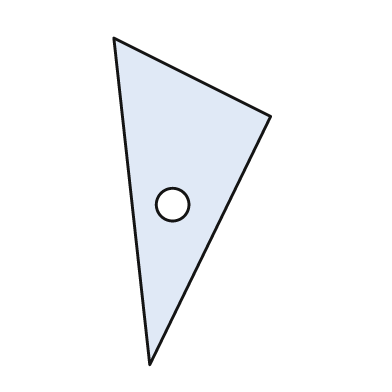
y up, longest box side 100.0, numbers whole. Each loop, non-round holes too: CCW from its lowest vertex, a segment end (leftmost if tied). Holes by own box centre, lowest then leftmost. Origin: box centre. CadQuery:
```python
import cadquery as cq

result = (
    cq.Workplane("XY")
    .moveTo(-13.0, -50.0)
    .lineTo(24.0, 26.0)
    .lineTo(-24.0, 50.0)
    .close()
    .moveTo(-6.0, -1.0)
    .circle(5.0)
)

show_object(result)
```